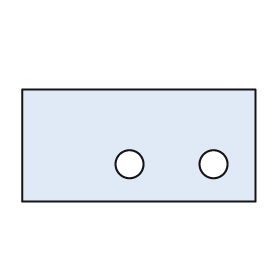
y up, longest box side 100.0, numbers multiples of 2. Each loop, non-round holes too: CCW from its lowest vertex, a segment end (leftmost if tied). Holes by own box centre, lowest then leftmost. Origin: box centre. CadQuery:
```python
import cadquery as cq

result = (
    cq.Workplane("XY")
    .moveTo(-50.0, -24.0)
    .lineTo(50.0, -24.0)
    .lineTo(50.0, 24.0)
    .lineTo(-50.0, 24.0)
    .close()
    .moveTo(-4.0, -8.0)
    .circle(6.0)
    .moveTo(32.0, -8.0)
    .circle(6.0)
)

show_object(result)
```